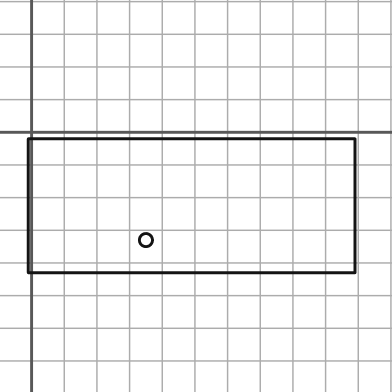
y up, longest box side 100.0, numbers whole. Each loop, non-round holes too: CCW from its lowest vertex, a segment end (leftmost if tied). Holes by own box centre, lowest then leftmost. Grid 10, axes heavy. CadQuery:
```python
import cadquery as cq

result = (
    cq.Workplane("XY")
    .moveTo(-1.0, -43.0)
    .lineTo(99.0, -43.0)
    .lineTo(99.0, -2.0)
    .lineTo(-1.0, -2.0)
    .close()
    .moveTo(35.0, -33.0)
    .circle(2.0)
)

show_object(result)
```